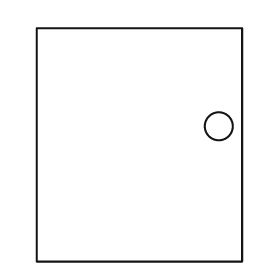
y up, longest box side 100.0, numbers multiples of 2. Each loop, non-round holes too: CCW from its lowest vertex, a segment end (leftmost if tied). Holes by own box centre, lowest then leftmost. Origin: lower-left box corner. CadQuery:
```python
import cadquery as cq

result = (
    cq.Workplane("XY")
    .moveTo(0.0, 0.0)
    .lineTo(88.0, 0.0)
    .lineTo(88.0, 100.0)
    .lineTo(0.0, 100.0)
    .close()
    .moveTo(78.0, 58.0)
    .circle(6.0)
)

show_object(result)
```